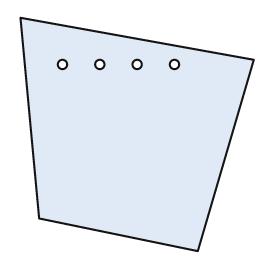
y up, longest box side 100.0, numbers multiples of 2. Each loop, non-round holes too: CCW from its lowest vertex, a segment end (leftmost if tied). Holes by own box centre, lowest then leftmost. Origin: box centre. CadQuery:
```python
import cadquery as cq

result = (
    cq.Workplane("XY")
    .moveTo(26.0, -50.0)
    .lineTo(50.0, 32.0)
    .lineTo(-50.0, 50.0)
    .lineTo(-42.0, -36.0)
    .close()
    .moveTo(-32.0, 30.0)
    .circle(2.0)
    .moveTo(-16.0, 30.0)
    .circle(2.0)
    .moveTo(0.0, 30.0)
    .circle(2.0)
    .moveTo(16.0, 30.0)
    .circle(2.0)
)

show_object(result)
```